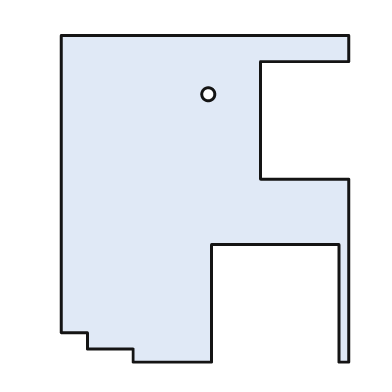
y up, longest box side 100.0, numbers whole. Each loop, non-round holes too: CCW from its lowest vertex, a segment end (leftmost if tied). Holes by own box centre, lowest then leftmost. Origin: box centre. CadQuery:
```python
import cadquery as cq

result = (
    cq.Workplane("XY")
    .moveTo(-22.0, -50.0)
    .lineTo(2.0, -50.0)
    .lineTo(2.0, -14.0)
    .lineTo(41.0, -14.0)
    .lineTo(41.0, -50.0)
    .lineTo(44.0, -50.0)
    .lineTo(44.0, 6.0)
    .lineTo(17.0, 6.0)
    .lineTo(17.0, 42.0)
    .lineTo(44.0, 42.0)
    .lineTo(44.0, 50.0)
    .lineTo(-44.0, 50.0)
    .lineTo(-44.0, -41.0)
    .lineTo(-36.0, -41.0)
    .lineTo(-36.0, -46.0)
    .lineTo(-22.0, -46.0)
    .close()
    .moveTo(1.0, 32.0)
    .circle(2.0)
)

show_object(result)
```